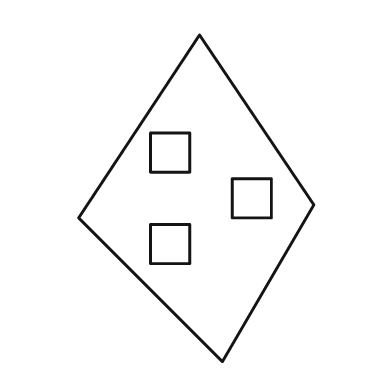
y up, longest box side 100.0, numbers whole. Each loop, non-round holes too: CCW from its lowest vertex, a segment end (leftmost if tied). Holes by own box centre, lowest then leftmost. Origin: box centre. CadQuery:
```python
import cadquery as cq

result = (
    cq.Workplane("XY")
    .moveTo(8.0, -50.0)
    .lineTo(36.0, -2.0)
    .lineTo(1.0, 50.0)
    .lineTo(-36.0, -6.0)
    .close()
    .moveTo(-14.0, -20.0)
    .lineTo(-2.0, -20.0)
    .lineTo(-2.0, -8.0)
    .lineTo(-14.0, -8.0)
    .close()
    .moveTo(11.0, -6.0)
    .lineTo(23.0, -6.0)
    .lineTo(23.0, 6.0)
    .lineTo(11.0, 6.0)
    .close()
    .moveTo(-14.0, 8.0)
    .lineTo(-2.0, 8.0)
    .lineTo(-2.0, 20.0)
    .lineTo(-14.0, 20.0)
    .close()
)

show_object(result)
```